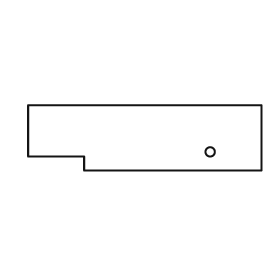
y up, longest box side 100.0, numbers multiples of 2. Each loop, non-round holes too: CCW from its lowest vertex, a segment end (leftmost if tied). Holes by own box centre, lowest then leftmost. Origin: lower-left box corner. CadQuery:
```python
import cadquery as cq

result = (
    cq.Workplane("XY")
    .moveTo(24.0, 0.0)
    .lineTo(100.0, 0.0)
    .lineTo(100.0, 28.0)
    .lineTo(0.0, 28.0)
    .lineTo(0.0, 6.0)
    .lineTo(24.0, 6.0)
    .close()
    .moveTo(78.0, 8.0)
    .circle(2.0)
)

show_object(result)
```